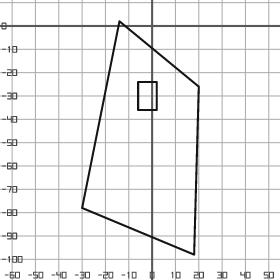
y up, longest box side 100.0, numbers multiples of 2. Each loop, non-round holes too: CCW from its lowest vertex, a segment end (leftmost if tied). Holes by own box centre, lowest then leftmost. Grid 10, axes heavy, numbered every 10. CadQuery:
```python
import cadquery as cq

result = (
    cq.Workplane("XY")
    .moveTo(18.0, -98.0)
    .lineTo(20.0, -26.0)
    .lineTo(-14.0, 2.0)
    .lineTo(-30.0, -78.0)
    .close()
    .moveTo(-6.0, -36.0)
    .lineTo(2.0, -36.0)
    .lineTo(2.0, -24.0)
    .lineTo(-6.0, -24.0)
    .close()
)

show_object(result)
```